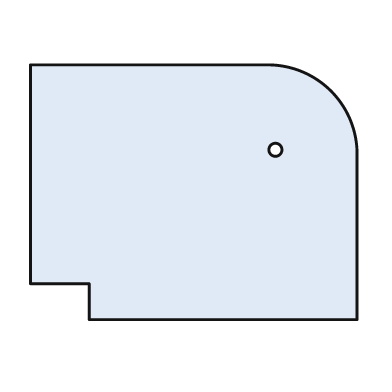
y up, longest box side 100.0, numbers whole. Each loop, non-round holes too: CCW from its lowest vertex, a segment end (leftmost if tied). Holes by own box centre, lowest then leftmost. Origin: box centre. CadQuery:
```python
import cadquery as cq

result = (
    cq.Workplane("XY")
    .moveTo(-32.0, -39.0)
    .lineTo(50.0, -39.0)
    .lineTo(50.0, 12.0)
    .threePointArc((42.0, 31.0), (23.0, 39.0))
    .lineTo(-50.0, 39.0)
    .lineTo(-50.0, -28.0)
    .lineTo(-32.0, -28.0)
    .close()
    .moveTo(25.0, 13.0)
    .circle(2.0)
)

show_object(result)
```